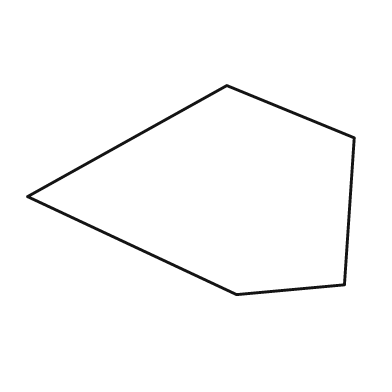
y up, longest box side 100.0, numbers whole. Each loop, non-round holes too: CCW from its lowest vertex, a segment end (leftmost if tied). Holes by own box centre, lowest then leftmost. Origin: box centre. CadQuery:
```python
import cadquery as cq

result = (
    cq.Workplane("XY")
    .moveTo(14.0, -32.0)
    .lineTo(47.0, -29.0)
    .lineTo(50.0, 16.0)
    .lineTo(11.0, 32.0)
    .lineTo(-50.0, -2.0)
    .close()
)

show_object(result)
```